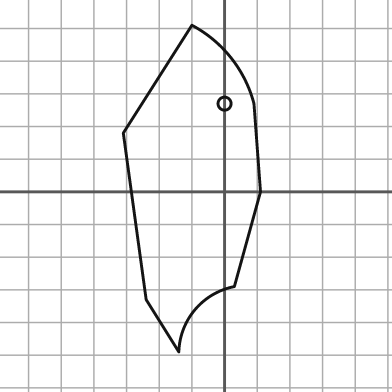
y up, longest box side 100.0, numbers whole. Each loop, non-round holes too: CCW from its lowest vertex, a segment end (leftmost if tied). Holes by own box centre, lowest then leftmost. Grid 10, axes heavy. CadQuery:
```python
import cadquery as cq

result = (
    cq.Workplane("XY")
    .moveTo(-14.0, -49.0)
    .threePointArc((-9.0, -36.0), (3.0, -29.0))
    .lineTo(11.0, 0.0)
    .lineTo(9.0, 27.0)
    .threePointArc((2.0, 41.0), (-10.0, 51.0))
    .lineTo(-31.0, 18.0)
    .lineTo(-24.0, -33.0)
    .close()
    .moveTo(0.0, 27.0)
    .circle(2.0)
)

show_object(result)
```